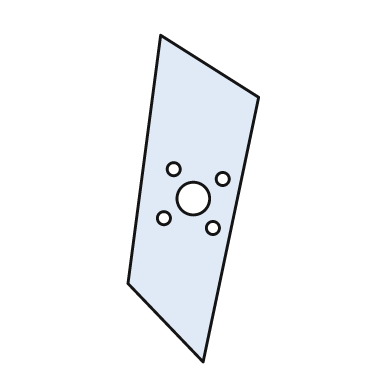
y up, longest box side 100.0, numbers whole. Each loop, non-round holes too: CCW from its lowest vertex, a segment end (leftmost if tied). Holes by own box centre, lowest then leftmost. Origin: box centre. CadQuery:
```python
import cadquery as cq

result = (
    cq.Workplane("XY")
    .moveTo(3.0, -50.0)
    .lineTo(20.0, 31.0)
    .lineTo(-10.0, 50.0)
    .lineTo(-20.0, -26.0)
    .close()
    .moveTo(6.0, -9.0)
    .circle(2.0)
    .moveTo(-9.0, -6.0)
    .circle(2.0)
    .moveTo(0.0, 0.0)
    .circle(5.0)
    .moveTo(9.0, 6.0)
    .circle(2.0)
    .moveTo(-6.0, 9.0)
    .circle(2.0)
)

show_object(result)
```